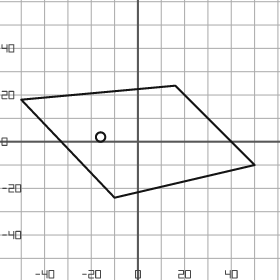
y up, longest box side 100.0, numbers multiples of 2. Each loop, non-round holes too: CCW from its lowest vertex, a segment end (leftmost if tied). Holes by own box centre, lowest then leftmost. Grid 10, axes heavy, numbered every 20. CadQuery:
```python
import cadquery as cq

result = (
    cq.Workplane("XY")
    .moveTo(-10.0, -24.0)
    .lineTo(50.0, -10.0)
    .lineTo(16.0, 24.0)
    .lineTo(-50.0, 18.0)
    .close()
    .moveTo(-16.0, 2.0)
    .circle(2.0)
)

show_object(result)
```